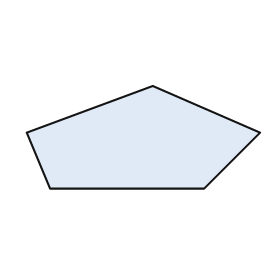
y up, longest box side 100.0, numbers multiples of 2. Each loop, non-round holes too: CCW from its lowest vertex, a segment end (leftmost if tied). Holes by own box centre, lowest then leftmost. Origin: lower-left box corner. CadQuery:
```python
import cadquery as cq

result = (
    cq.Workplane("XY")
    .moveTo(10.0, 0.0)
    .lineTo(76.0, 0.0)
    .lineTo(100.0, 24.0)
    .lineTo(54.0, 44.0)
    .lineTo(0.0, 24.0)
    .close()
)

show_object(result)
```